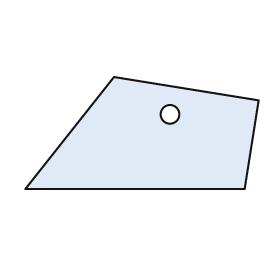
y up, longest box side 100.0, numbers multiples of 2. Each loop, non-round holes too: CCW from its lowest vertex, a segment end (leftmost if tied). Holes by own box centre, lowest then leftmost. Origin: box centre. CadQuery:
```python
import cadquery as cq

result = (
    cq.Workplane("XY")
    .moveTo(-50.0, -24.0)
    .lineTo(44.0, -24.0)
    .lineTo(50.0, 14.0)
    .lineTo(-12.0, 24.0)
    .close()
    .moveTo(12.0, 8.0)
    .circle(4.0)
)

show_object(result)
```